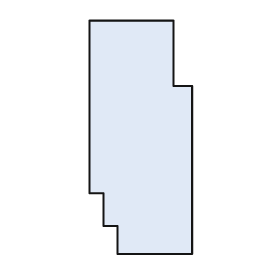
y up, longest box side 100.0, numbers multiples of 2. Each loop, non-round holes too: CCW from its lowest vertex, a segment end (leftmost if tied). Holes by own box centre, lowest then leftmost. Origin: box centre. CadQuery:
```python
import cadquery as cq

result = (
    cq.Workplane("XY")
    .moveTo(-10.0, -50.0)
    .lineTo(22.0, -50.0)
    .lineTo(22.0, 22.0)
    .lineTo(14.0, 22.0)
    .lineTo(14.0, 50.0)
    .lineTo(-22.0, 50.0)
    .lineTo(-22.0, -24.0)
    .lineTo(-16.0, -24.0)
    .lineTo(-16.0, -38.0)
    .lineTo(-10.0, -38.0)
    .close()
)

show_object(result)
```